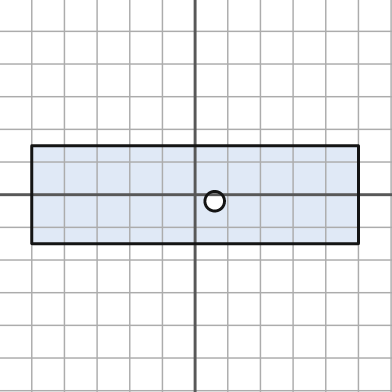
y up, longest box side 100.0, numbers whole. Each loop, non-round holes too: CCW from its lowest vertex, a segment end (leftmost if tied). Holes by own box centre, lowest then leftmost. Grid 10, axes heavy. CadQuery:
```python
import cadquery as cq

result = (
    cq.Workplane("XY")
    .moveTo(-50.0, -15.0)
    .lineTo(50.0, -15.0)
    .lineTo(50.0, 15.0)
    .lineTo(-50.0, 15.0)
    .close()
    .moveTo(6.0, -2.0)
    .circle(3.0)
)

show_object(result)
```